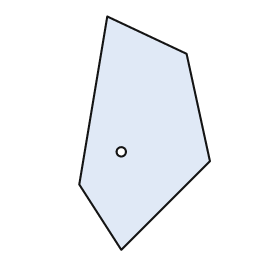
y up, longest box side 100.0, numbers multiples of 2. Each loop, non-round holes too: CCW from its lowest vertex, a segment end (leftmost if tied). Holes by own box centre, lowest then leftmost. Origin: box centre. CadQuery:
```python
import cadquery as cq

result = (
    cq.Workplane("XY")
    .moveTo(-10.0, -50.0)
    .lineTo(28.0, -12.0)
    .lineTo(18.0, 34.0)
    .lineTo(-16.0, 50.0)
    .lineTo(-28.0, -22.0)
    .close()
    .moveTo(-10.0, -8.0)
    .circle(2.0)
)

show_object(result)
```